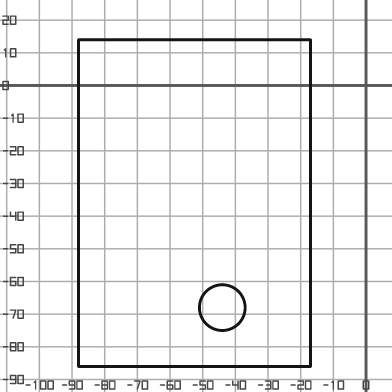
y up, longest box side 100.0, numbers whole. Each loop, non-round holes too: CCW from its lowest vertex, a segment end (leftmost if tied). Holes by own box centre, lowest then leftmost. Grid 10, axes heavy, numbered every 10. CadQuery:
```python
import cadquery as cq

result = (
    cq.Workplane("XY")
    .moveTo(-88.0, -86.0)
    .lineTo(-17.0, -86.0)
    .lineTo(-17.0, 14.0)
    .lineTo(-88.0, 14.0)
    .close()
    .moveTo(-44.0, -68.0)
    .circle(7.0)
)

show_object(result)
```